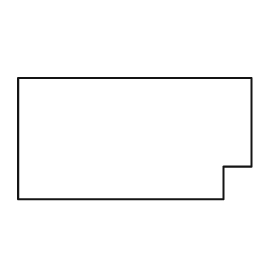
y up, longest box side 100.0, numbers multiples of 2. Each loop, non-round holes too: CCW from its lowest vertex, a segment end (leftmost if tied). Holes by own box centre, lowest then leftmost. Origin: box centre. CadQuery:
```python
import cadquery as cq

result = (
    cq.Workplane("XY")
    .moveTo(-50.0, -26.0)
    .lineTo(38.0, -26.0)
    .lineTo(38.0, -12.0)
    .lineTo(50.0, -12.0)
    .lineTo(50.0, 26.0)
    .lineTo(-50.0, 26.0)
    .close()
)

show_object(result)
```